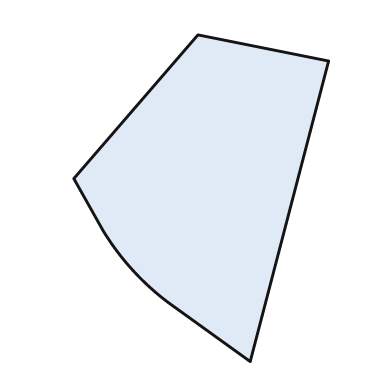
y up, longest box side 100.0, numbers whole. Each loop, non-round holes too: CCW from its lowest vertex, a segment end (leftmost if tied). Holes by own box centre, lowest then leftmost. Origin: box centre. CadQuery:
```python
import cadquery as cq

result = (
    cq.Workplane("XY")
    .moveTo(15.0, -50.0)
    .lineTo(39.0, 42.0)
    .lineTo(-1.0, 50.0)
    .lineTo(-39.0, 6.0)
    .lineTo(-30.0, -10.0)
    .threePointArc((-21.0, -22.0), (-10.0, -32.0))
    .close()
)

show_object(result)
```